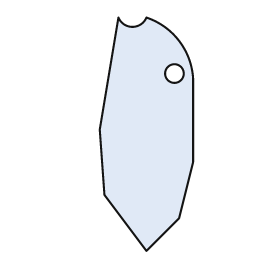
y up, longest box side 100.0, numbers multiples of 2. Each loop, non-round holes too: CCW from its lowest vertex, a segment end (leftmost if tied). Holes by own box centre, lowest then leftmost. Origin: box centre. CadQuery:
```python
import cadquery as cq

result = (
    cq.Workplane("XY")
    .moveTo(0.0, -50.0)
    .lineTo(14.0, -36.0)
    .lineTo(20.0, -12.0)
    .lineTo(20.0, 24.0)
    .threePointArc((14.0, 40.0), (0.0, 50.0))
    .threePointArc((-6.0, 46.0), (-12.0, 50.0))
    .lineTo(-20.0, 2.0)
    .lineTo(-18.0, -26.0)
    .close()
    .moveTo(12.0, 26.0)
    .circle(4.0)
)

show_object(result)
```